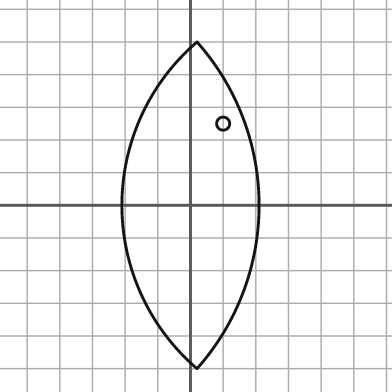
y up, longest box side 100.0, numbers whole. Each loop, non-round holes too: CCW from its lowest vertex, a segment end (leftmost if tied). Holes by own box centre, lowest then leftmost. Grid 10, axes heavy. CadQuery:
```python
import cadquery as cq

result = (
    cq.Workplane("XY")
    .moveTo(2.0, -50.0)
    .threePointArc((21.0, 0.0), (2.0, 50.0))
    .threePointArc((-21.0, 0.0), (2.0, -50.0))
    .close()
    .moveTo(10.0, 25.0)
    .circle(2.0)
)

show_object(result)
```